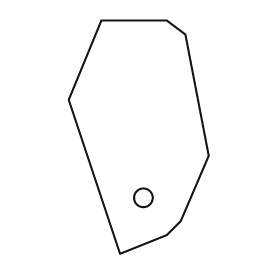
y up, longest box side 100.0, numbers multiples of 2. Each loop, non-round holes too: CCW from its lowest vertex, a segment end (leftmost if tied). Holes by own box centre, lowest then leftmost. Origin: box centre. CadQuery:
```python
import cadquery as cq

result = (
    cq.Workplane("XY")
    .moveTo(-8.0, -50.0)
    .lineTo(12.0, -42.0)
    .lineTo(18.0, -36.0)
    .lineTo(30.0, -8.0)
    .lineTo(20.0, 44.0)
    .lineTo(12.0, 50.0)
    .lineTo(-16.0, 50.0)
    .lineTo(-30.0, 16.0)
    .close()
    .moveTo(2.0, -26.0)
    .circle(4.0)
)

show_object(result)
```